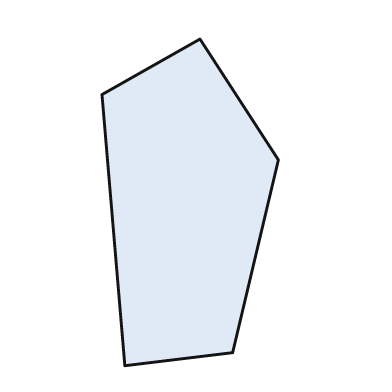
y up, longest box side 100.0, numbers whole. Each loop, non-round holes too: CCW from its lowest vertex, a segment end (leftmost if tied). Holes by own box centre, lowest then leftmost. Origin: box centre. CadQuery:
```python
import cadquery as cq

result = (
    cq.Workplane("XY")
    .moveTo(-20.0, -50.0)
    .lineTo(13.0, -46.0)
    .lineTo(27.0, 13.0)
    .lineTo(3.0, 50.0)
    .lineTo(-27.0, 33.0)
    .close()
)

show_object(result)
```